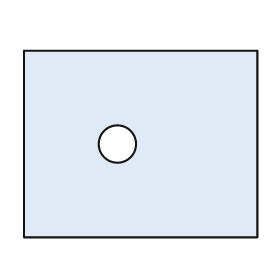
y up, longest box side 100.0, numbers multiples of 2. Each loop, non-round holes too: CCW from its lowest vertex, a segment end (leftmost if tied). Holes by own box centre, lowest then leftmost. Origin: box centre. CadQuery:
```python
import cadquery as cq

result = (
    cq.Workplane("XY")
    .moveTo(-50.0, -40.0)
    .lineTo(50.0, -40.0)
    .lineTo(50.0, 40.0)
    .lineTo(-50.0, 40.0)
    .close()
    .moveTo(-10.0, 0.0)
    .circle(8.0)
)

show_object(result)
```